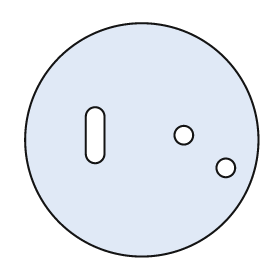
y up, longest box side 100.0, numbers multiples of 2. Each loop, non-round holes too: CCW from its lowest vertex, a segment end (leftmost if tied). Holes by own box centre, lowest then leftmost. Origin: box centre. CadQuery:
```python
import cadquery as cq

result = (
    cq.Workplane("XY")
    .moveTo(0.0, 0.0)
    .circle(50.0)
    .moveTo(36.0, -12.0)
    .circle(4.0)
    .moveTo(-24.0, -6.0)
    .threePointArc((-20.0, -10.0), (-16.0, -6.0))
    .lineTo(-16.0, 10.0)
    .threePointArc((-20.0, 14.0), (-24.0, 10.0))
    .close()
    .moveTo(18.0, 2.0)
    .circle(4.0)
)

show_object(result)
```